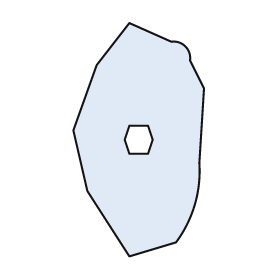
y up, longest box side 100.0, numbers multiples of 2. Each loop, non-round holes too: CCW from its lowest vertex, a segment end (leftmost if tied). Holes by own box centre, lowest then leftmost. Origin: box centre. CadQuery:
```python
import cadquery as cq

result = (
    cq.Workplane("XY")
    .moveTo(-4.0, -50.0)
    .lineTo(16.0, -44.0)
    .threePointArc((24.0, -28.0), (26.0, -10.0))
    .lineTo(28.0, 22.0)
    .lineTo(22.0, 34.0)
    .threePointArc((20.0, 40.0), (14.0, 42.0))
    .lineTo(-4.0, 50.0)
    .lineTo(-18.0, 32.0)
    .lineTo(-28.0, 4.0)
    .lineTo(-22.0, -22.0)
    .close()
    .moveTo(-4.0, -6.0)
    .lineTo(4.0, -6.0)
    .lineTo(6.0, 0.0)
    .lineTo(4.0, 6.0)
    .lineTo(-4.0, 6.0)
    .lineTo(-6.0, 0.0)
    .close()
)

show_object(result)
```